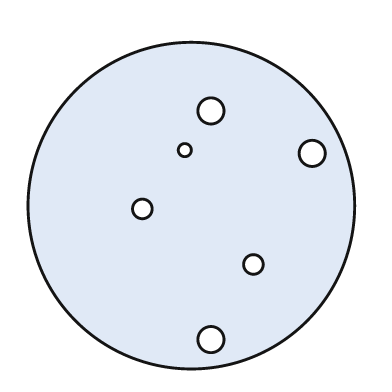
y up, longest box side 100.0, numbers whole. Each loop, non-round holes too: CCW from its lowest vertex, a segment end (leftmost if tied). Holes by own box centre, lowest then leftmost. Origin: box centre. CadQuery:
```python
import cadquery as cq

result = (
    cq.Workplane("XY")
    .moveTo(0.0, 0.0)
    .circle(50.0)
    .moveTo(6.0, -41.0)
    .circle(4.0)
    .moveTo(19.0, -18.0)
    .circle(3.0)
    .moveTo(-15.0, -1.0)
    .circle(3.0)
    .moveTo(37.0, 16.0)
    .circle(4.0)
    .moveTo(-2.0, 17.0)
    .circle(2.0)
    .moveTo(6.0, 29.0)
    .circle(4.0)
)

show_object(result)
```